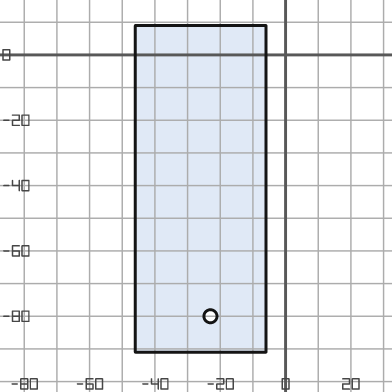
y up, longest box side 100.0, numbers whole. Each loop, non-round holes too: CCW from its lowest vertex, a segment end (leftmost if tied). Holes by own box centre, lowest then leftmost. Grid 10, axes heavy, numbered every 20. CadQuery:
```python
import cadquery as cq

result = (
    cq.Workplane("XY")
    .moveTo(-46.0, -91.0)
    .lineTo(-6.0, -91.0)
    .lineTo(-6.0, 9.0)
    .lineTo(-46.0, 9.0)
    .close()
    .moveTo(-23.0, -80.0)
    .circle(2.0)
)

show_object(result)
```